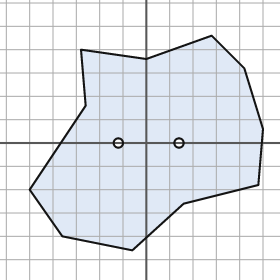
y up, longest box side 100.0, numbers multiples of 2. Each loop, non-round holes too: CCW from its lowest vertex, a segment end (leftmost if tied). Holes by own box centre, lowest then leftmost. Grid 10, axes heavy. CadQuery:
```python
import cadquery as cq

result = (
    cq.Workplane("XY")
    .moveTo(-6.0, -46.0)
    .lineTo(16.0, -26.0)
    .lineTo(48.0, -18.0)
    .lineTo(50.0, 6.0)
    .lineTo(42.0, 32.0)
    .lineTo(28.0, 46.0)
    .lineTo(0.0, 36.0)
    .lineTo(-28.0, 40.0)
    .lineTo(-26.0, 16.0)
    .lineTo(-50.0, -20.0)
    .lineTo(-36.0, -40.0)
    .close()
    .moveTo(-12.0, 0.0)
    .circle(2.0)
    .moveTo(14.0, 0.0)
    .circle(2.0)
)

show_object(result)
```